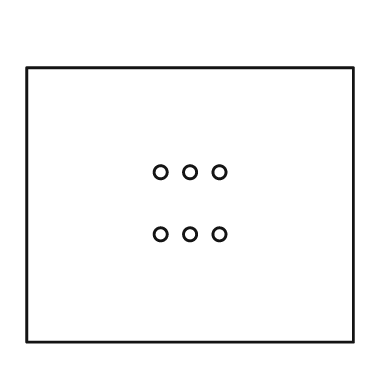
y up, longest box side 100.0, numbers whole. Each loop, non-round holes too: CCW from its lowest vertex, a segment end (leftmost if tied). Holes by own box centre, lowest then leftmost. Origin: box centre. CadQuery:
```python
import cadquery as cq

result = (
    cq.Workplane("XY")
    .moveTo(-50.0, -42.0)
    .lineTo(50.0, -42.0)
    .lineTo(50.0, 42.0)
    .lineTo(-50.0, 42.0)
    .close()
    .moveTo(-9.0, -9.0)
    .circle(2.0)
    .moveTo(0.0, -9.0)
    .circle(2.0)
    .moveTo(9.0, -9.0)
    .circle(2.0)
    .moveTo(-9.0, 10.0)
    .circle(2.0)
    .moveTo(0.0, 10.0)
    .circle(2.0)
    .moveTo(9.0, 10.0)
    .circle(2.0)
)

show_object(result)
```